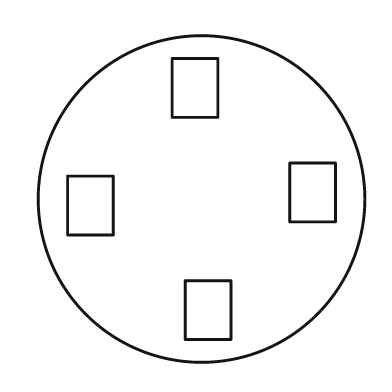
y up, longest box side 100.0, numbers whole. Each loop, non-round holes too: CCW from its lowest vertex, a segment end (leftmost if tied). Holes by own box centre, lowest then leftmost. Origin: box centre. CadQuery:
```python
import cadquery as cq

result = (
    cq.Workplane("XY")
    .moveTo(0.0, 0.0)
    .circle(50.0)
    .moveTo(-5.0, -43.0)
    .lineTo(9.0, -43.0)
    .lineTo(9.0, -25.0)
    .lineTo(-5.0, -25.0)
    .close()
    .moveTo(-41.0, -11.0)
    .lineTo(-27.0, -11.0)
    .lineTo(-27.0, 7.0)
    .lineTo(-41.0, 7.0)
    .close()
    .moveTo(27.0, -7.0)
    .lineTo(41.0, -7.0)
    .lineTo(41.0, 11.0)
    .lineTo(27.0, 11.0)
    .close()
    .moveTo(-9.0, 25.0)
    .lineTo(5.0, 25.0)
    .lineTo(5.0, 43.0)
    .lineTo(-9.0, 43.0)
    .close()
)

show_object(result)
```